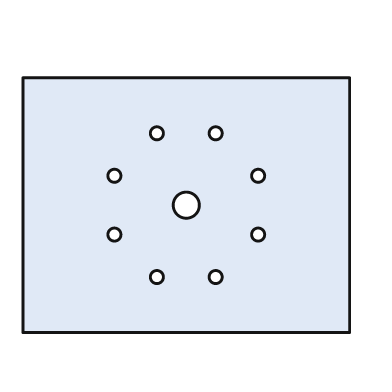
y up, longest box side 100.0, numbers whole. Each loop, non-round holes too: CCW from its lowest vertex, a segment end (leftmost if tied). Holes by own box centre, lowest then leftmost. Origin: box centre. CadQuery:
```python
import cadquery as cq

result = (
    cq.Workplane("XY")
    .moveTo(-50.0, -39.0)
    .lineTo(50.0, -39.0)
    .lineTo(50.0, 39.0)
    .lineTo(-50.0, 39.0)
    .close()
    .moveTo(-9.0, -22.0)
    .circle(2.0)
    .moveTo(9.0, -22.0)
    .circle(2.0)
    .moveTo(-22.0, -9.0)
    .circle(2.0)
    .moveTo(22.0, -9.0)
    .circle(2.0)
    .moveTo(0.0, 0.0)
    .circle(4.0)
    .moveTo(-22.0, 9.0)
    .circle(2.0)
    .moveTo(22.0, 9.0)
    .circle(2.0)
    .moveTo(-9.0, 22.0)
    .circle(2.0)
    .moveTo(9.0, 22.0)
    .circle(2.0)
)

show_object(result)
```